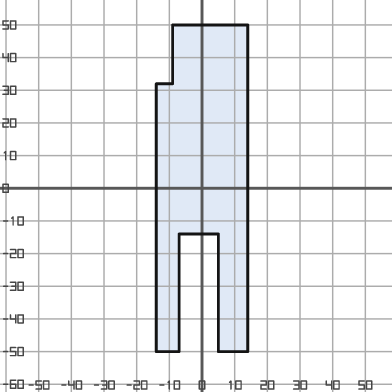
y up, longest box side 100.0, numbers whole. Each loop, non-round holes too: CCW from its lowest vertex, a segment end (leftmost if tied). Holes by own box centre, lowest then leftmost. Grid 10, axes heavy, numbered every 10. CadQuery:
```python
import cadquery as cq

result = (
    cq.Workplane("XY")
    .moveTo(-14.0, -50.0)
    .lineTo(-7.0, -50.0)
    .lineTo(-7.0, -14.0)
    .lineTo(5.0, -14.0)
    .lineTo(5.0, -50.0)
    .lineTo(14.0, -50.0)
    .lineTo(14.0, 50.0)
    .lineTo(-9.0, 50.0)
    .lineTo(-9.0, 32.0)
    .lineTo(-14.0, 32.0)
    .close()
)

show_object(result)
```